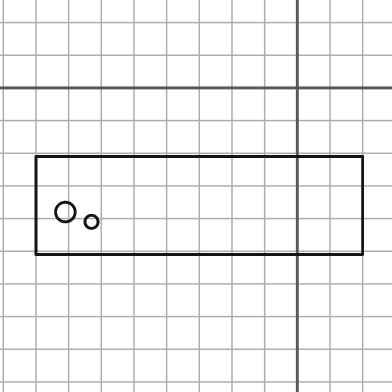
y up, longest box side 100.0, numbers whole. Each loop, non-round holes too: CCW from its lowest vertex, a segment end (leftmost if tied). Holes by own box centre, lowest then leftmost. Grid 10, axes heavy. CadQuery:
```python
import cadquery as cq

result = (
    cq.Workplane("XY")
    .moveTo(-80.0, -51.0)
    .lineTo(20.0, -51.0)
    .lineTo(20.0, -21.0)
    .lineTo(-80.0, -21.0)
    .close()
    .moveTo(-63.0, -41.0)
    .circle(2.0)
    .moveTo(-71.0, -38.0)
    .circle(3.0)
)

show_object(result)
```